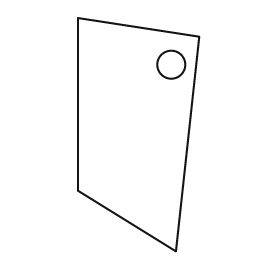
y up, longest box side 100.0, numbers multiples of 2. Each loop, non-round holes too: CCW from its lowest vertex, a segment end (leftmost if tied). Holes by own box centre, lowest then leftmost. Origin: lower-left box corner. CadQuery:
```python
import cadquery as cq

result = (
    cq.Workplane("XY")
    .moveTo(42.0, 0.0)
    .lineTo(52.0, 92.0)
    .lineTo(0.0, 100.0)
    .lineTo(0.0, 26.0)
    .close()
    .moveTo(40.0, 80.0)
    .circle(6.0)
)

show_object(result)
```